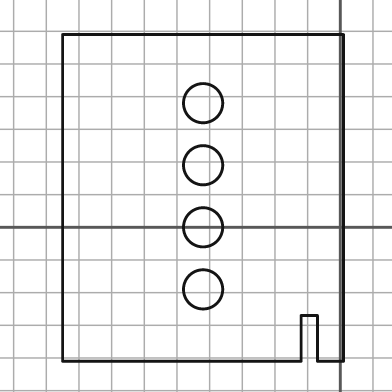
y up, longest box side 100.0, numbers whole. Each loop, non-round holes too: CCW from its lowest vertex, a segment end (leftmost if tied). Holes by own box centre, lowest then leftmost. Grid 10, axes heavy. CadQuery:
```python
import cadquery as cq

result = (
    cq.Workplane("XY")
    .moveTo(-85.0, -41.0)
    .lineTo(-12.0, -41.0)
    .lineTo(-12.0, -27.0)
    .lineTo(-7.0, -27.0)
    .lineTo(-7.0, -41.0)
    .lineTo(1.0, -41.0)
    .lineTo(1.0, 59.0)
    .lineTo(-85.0, 59.0)
    .close()
    .moveTo(-42.0, -19.0)
    .circle(6.0)
    .moveTo(-42.0, 0.0)
    .circle(6.0)
    .moveTo(-42.0, 19.0)
    .circle(6.0)
    .moveTo(-42.0, 38.0)
    .circle(6.0)
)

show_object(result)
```